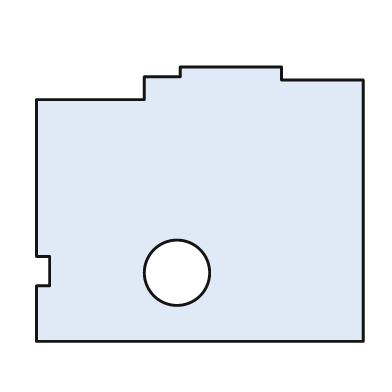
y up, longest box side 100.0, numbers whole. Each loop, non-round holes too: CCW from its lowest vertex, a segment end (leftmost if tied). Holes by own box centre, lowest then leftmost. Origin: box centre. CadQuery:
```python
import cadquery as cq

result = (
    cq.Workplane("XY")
    .moveTo(-50.0, -42.0)
    .lineTo(50.0, -42.0)
    .lineTo(50.0, 38.0)
    .lineTo(25.0, 38.0)
    .lineTo(25.0, 42.0)
    .lineTo(-6.0, 42.0)
    .lineTo(-6.0, 39.0)
    .lineTo(-17.0, 39.0)
    .lineTo(-17.0, 32.0)
    .lineTo(-50.0, 32.0)
    .lineTo(-50.0, -16.0)
    .lineTo(-46.0, -16.0)
    .lineTo(-46.0, -25.0)
    .lineTo(-50.0, -25.0)
    .close()
    .moveTo(-7.0, -21.0)
    .circle(10.0)
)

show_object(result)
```